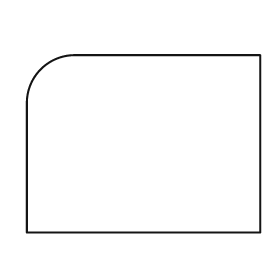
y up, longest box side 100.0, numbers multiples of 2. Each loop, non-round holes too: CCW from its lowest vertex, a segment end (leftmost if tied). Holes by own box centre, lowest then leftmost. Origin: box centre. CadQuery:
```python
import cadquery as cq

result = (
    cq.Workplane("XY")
    .moveTo(-50.0, -38.0)
    .lineTo(50.0, -38.0)
    .lineTo(50.0, 38.0)
    .lineTo(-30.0, 38.0)
    .threePointArc((-44.0, 32.0), (-50.0, 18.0))
    .close()
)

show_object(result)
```